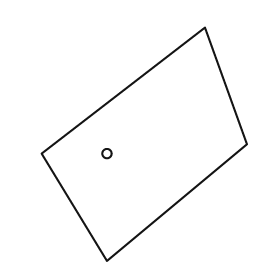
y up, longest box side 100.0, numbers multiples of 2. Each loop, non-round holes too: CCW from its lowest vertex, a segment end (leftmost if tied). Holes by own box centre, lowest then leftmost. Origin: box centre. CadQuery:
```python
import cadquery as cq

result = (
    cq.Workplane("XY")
    .moveTo(-16.0, -50.0)
    .lineTo(44.0, 0.0)
    .lineTo(26.0, 50.0)
    .lineTo(-44.0, -4.0)
    .close()
    .moveTo(-16.0, -4.0)
    .circle(2.0)
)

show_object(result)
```